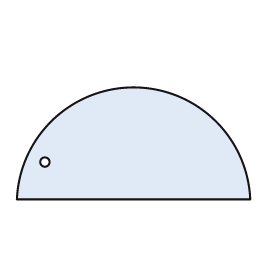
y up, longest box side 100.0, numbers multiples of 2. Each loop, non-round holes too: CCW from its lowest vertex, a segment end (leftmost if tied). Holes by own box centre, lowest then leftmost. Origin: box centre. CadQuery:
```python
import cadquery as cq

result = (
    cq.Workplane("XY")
    .moveTo(-50.0, -24.0)
    .lineTo(50.0, -24.0)
    .threePointArc((0.0, 24.0), (-50.0, -24.0))
    .close()
    .moveTo(-38.0, -8.0)
    .circle(2.0)
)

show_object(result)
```